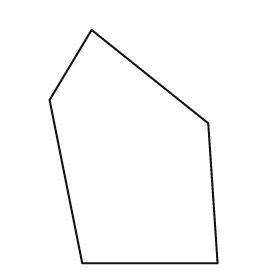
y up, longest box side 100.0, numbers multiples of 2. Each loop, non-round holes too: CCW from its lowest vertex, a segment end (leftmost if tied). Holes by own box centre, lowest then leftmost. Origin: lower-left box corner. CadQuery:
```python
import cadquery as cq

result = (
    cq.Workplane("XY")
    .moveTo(14.0, 0.0)
    .lineTo(72.0, 0.0)
    .lineTo(68.0, 60.0)
    .lineTo(18.0, 100.0)
    .lineTo(0.0, 70.0)
    .close()
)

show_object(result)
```